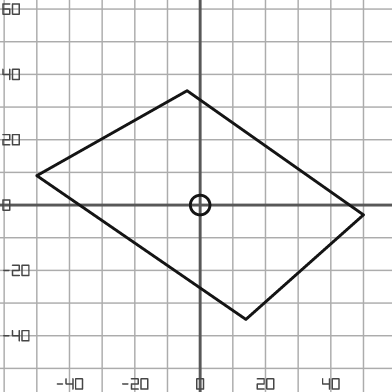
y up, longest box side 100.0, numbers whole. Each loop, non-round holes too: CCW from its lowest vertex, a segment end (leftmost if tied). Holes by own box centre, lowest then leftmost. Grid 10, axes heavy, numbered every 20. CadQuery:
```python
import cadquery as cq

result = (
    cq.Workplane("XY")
    .moveTo(14.0, -35.0)
    .lineTo(50.0, -3.0)
    .lineTo(-4.0, 35.0)
    .lineTo(-50.0, 9.0)
    .close()
    .moveTo(0.0, 0.0)
    .circle(3.0)
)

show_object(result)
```